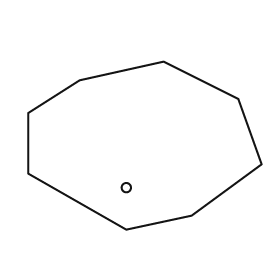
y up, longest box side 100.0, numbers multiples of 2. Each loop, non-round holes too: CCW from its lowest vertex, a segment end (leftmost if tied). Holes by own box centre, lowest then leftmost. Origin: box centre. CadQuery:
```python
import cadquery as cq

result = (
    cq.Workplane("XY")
    .moveTo(-8.0, -36.0)
    .lineTo(20.0, -30.0)
    .lineTo(50.0, -8.0)
    .lineTo(40.0, 20.0)
    .lineTo(8.0, 36.0)
    .lineTo(-28.0, 28.0)
    .lineTo(-50.0, 14.0)
    .lineTo(-50.0, -12.0)
    .close()
    .moveTo(-8.0, -18.0)
    .circle(2.0)
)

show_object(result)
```